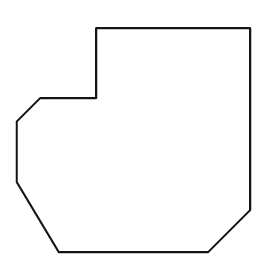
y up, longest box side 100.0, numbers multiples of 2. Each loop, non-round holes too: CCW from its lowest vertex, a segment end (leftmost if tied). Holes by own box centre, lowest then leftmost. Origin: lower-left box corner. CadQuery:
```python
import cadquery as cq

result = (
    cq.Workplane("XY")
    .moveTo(18.0, 0.0)
    .lineTo(82.0, 0.0)
    .lineTo(100.0, 18.0)
    .lineTo(100.0, 96.0)
    .lineTo(34.0, 96.0)
    .lineTo(34.0, 66.0)
    .lineTo(10.0, 66.0)
    .lineTo(0.0, 56.0)
    .lineTo(0.0, 30.0)
    .close()
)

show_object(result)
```